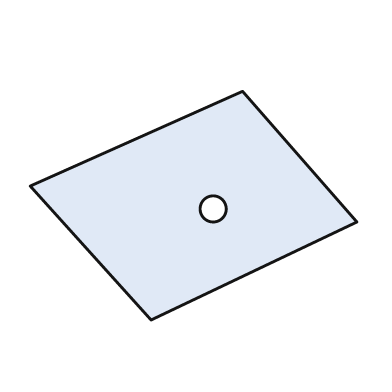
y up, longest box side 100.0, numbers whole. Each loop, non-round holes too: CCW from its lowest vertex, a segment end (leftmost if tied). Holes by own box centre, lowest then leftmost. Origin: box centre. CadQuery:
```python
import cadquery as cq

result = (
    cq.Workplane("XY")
    .moveTo(-13.0, -35.0)
    .lineTo(50.0, -5.0)
    .lineTo(15.0, 35.0)
    .lineTo(-50.0, 6.0)
    .close()
    .moveTo(6.0, -1.0)
    .circle(4.0)
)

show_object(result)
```